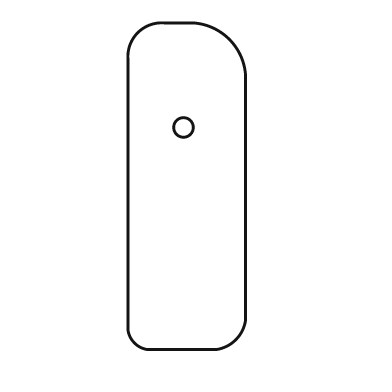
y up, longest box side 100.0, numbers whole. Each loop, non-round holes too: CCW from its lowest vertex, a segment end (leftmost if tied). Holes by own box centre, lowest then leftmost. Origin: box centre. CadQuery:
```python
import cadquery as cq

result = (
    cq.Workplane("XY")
    .moveTo(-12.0, -50.0)
    .lineTo(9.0, -50.0)
    .threePointArc((15.0, -47.0), (18.0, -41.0))
    .lineTo(18.0, 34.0)
    .threePointArc((13.0, 45.0), (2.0, 50.0))
    .lineTo(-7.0, 50.0)
    .threePointArc((-15.0, 47.0), (-18.0, 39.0))
    .lineTo(-18.0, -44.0)
    .threePointArc((-16.0, -48.0), (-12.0, -50.0))
    .close()
    .moveTo(-1.0, 18.0)
    .circle(3.0)
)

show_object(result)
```